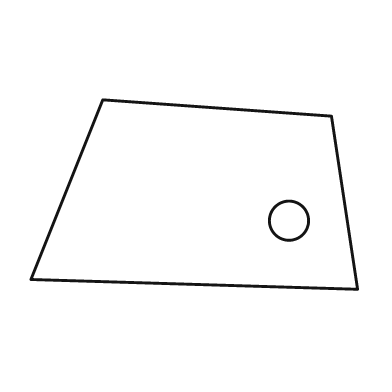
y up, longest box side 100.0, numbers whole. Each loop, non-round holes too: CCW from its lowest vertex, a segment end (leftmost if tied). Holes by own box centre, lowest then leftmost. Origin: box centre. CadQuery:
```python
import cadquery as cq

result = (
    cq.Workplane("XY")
    .moveTo(50.0, -29.0)
    .lineTo(42.0, 24.0)
    .lineTo(-28.0, 29.0)
    .lineTo(-50.0, -26.0)
    .close()
    .moveTo(29.0, -8.0)
    .circle(6.0)
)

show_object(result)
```